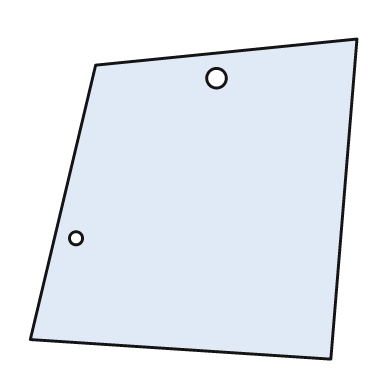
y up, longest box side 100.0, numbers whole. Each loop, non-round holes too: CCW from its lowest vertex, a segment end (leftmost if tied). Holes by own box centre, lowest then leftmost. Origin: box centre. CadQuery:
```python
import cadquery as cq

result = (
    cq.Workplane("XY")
    .moveTo(42.0, -49.0)
    .lineTo(50.0, 49.0)
    .lineTo(-30.0, 41.0)
    .lineTo(-50.0, -43.0)
    .close()
    .moveTo(-36.0, -12.0)
    .circle(2.0)
    .moveTo(7.0, 37.0)
    .circle(3.0)
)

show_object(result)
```